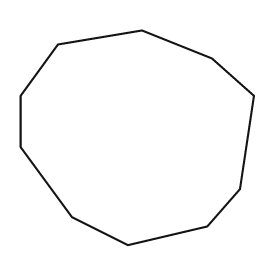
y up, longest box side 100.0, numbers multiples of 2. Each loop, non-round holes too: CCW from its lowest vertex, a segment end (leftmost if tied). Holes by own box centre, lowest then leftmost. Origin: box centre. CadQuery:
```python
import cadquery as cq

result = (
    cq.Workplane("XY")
    .moveTo(-4.0, -46.0)
    .lineTo(30.0, -38.0)
    .lineTo(44.0, -22.0)
    .lineTo(50.0, 18.0)
    .lineTo(32.0, 34.0)
    .lineTo(2.0, 46.0)
    .lineTo(-34.0, 40.0)
    .lineTo(-50.0, 18.0)
    .lineTo(-50.0, -4.0)
    .lineTo(-28.0, -34.0)
    .close()
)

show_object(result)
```